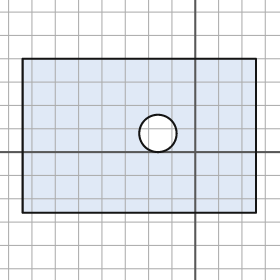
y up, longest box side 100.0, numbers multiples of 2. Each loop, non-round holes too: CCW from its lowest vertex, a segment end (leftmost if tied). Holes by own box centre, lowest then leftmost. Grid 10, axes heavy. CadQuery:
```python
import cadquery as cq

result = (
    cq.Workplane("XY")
    .moveTo(-74.0, -26.0)
    .lineTo(26.0, -26.0)
    .lineTo(26.0, 40.0)
    .lineTo(-74.0, 40.0)
    .close()
    .moveTo(-16.0, 8.0)
    .circle(8.0)
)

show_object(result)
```